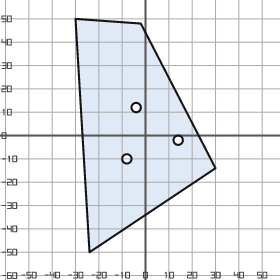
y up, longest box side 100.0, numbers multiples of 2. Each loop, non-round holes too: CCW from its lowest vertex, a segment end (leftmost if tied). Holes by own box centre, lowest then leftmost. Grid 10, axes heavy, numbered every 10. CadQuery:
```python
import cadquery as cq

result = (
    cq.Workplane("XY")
    .moveTo(-24.0, -50.0)
    .lineTo(30.0, -14.0)
    .lineTo(-2.0, 48.0)
    .lineTo(-30.0, 50.0)
    .close()
    .moveTo(-8.0, -10.0)
    .circle(2.0)
    .moveTo(14.0, -2.0)
    .circle(2.0)
    .moveTo(-4.0, 12.0)
    .circle(2.0)
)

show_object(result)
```